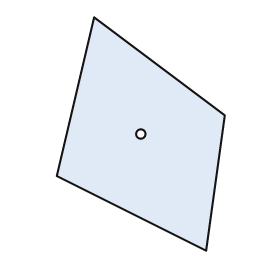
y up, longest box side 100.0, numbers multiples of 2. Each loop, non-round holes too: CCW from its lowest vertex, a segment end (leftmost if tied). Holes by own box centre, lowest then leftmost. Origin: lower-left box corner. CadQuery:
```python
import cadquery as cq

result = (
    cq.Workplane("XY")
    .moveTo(64.0, 0.0)
    .lineTo(72.0, 58.0)
    .lineTo(16.0, 100.0)
    .lineTo(0.0, 32.0)
    .close()
    .moveTo(36.0, 50.0)
    .circle(2.0)
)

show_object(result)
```